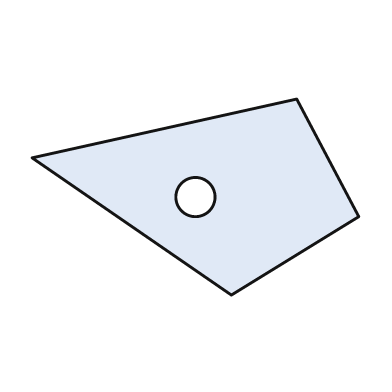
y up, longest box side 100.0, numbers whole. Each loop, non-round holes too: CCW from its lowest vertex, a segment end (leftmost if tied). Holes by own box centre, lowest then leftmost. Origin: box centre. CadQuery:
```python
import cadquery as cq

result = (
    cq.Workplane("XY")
    .moveTo(11.0, -30.0)
    .lineTo(50.0, -6.0)
    .lineTo(31.0, 30.0)
    .lineTo(-50.0, 12.0)
    .close()
    .moveTo(0.0, 0.0)
    .circle(6.0)
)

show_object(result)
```